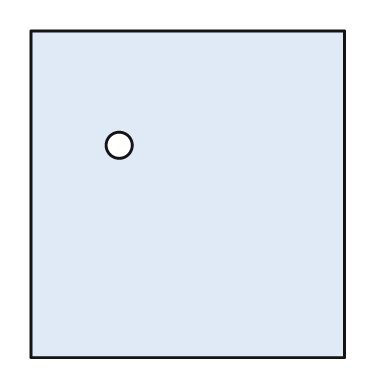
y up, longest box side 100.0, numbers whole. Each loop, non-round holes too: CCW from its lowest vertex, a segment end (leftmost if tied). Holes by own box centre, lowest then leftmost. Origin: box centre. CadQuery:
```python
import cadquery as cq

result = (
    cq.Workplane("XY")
    .moveTo(-48.0, -50.0)
    .lineTo(48.0, -50.0)
    .lineTo(48.0, 50.0)
    .lineTo(-48.0, 50.0)
    .close()
    .moveTo(-21.0, 15.0)
    .circle(4.0)
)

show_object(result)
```